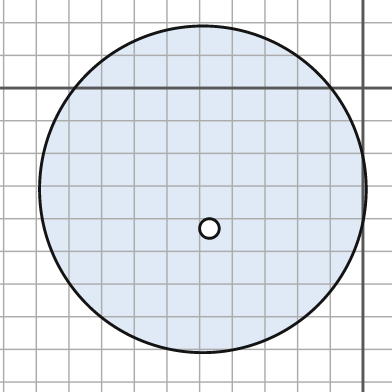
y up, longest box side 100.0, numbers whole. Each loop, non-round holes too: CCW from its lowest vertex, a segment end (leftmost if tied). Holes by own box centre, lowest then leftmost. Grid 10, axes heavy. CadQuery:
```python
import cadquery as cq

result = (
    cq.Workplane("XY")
    .moveTo(-49.0, -31.0)
    .circle(50.0)
    .moveTo(-47.0, -43.0)
    .circle(3.0)
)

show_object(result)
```